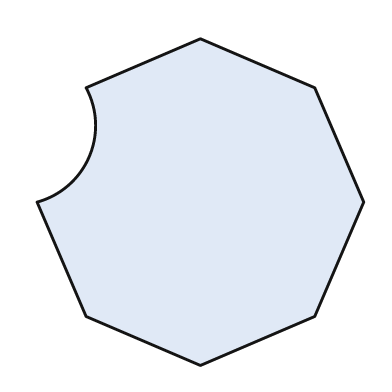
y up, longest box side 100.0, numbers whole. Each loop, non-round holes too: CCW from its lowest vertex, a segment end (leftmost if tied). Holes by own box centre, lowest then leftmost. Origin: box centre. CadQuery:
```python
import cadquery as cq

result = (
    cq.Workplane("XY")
    .moveTo(0.0, -50.0)
    .lineTo(35.0, -35.0)
    .lineTo(50.0, 0.0)
    .lineTo(35.0, 35.0)
    .lineTo(0.0, 50.0)
    .lineTo(-35.0, 35.0)
    .threePointArc((-34.0, 14.0), (-50.0, 0.0))
    .lineTo(-35.0, -35.0)
    .close()
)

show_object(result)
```